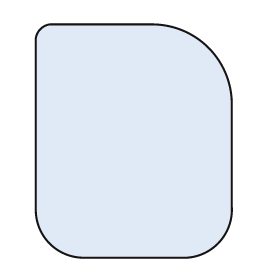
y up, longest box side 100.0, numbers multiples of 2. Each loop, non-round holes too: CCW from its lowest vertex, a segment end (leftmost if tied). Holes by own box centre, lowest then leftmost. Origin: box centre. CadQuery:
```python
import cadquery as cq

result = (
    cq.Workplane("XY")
    .moveTo(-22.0, -50.0)
    .lineTo(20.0, -50.0)
    .threePointArc((36.0, -44.0), (42.0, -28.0))
    .lineTo(42.0, 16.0)
    .threePointArc((32.0, 40.0), (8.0, 50.0))
    .lineTo(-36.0, 50.0)
    .threePointArc((-40.0, 48.0), (-42.0, 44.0))
    .lineTo(-42.0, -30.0)
    .threePointArc((-36.0, -44.0), (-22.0, -50.0))
    .close()
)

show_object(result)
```